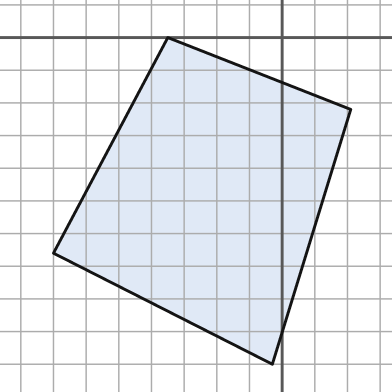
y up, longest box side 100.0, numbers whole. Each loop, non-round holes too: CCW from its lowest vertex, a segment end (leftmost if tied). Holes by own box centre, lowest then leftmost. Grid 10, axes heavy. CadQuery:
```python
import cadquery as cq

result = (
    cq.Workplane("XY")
    .moveTo(-3.0, -100.0)
    .lineTo(21.0, -22.0)
    .lineTo(-35.0, 0.0)
    .lineTo(-70.0, -66.0)
    .close()
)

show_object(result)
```